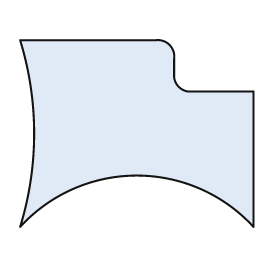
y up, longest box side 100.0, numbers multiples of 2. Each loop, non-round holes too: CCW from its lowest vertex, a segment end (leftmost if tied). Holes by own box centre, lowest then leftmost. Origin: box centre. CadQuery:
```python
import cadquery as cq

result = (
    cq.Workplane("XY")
    .moveTo(-50.0, -40.0)
    .threePointArc((0.0, -18.0), (50.0, -40.0))
    .lineTo(50.0, 18.0)
    .lineTo(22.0, 18.0)
    .threePointArc((18.0, 20.0), (16.0, 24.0))
    .lineTo(16.0, 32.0)
    .threePointArc((14.0, 38.0), (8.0, 40.0))
    .lineTo(-50.0, 40.0)
    .threePointArc((-44.0, 0.0), (-50.0, -40.0))
    .close()
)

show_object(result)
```